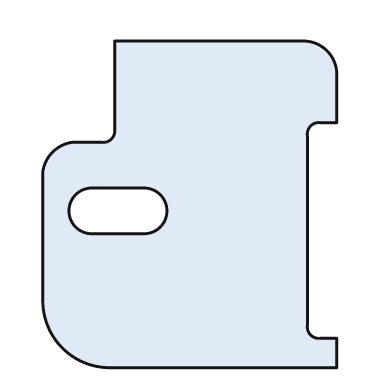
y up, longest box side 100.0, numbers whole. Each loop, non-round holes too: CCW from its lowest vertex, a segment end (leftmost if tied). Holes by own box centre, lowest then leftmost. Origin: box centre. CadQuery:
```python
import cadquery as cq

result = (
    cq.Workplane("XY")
    .moveTo(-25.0, -50.0)
    .lineTo(45.0, -50.0)
    .lineTo(45.0, -41.0)
    .lineTo(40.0, -41.0)
    .threePointArc((37.0, -40.0), (36.0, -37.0))
    .lineTo(36.0, 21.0)
    .threePointArc((37.0, 24.0), (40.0, 25.0))
    .lineTo(45.0, 25.0)
    .lineTo(45.0, 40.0)
    .threePointArc((42.0, 47.0), (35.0, 50.0))
    .lineTo(-23.0, 50.0)
    .lineTo(-23.0, 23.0)
    .threePointArc((-24.0, 20.0), (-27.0, 19.0))
    .lineTo(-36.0, 19.0)
    .threePointArc((-42.0, 16.0), (-45.0, 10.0))
    .lineTo(-45.0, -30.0)
    .threePointArc((-39.0, -44.0), (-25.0, -50.0))
    .close()
    .moveTo(-30.0, -9.0)
    .lineTo(-14.0, -9.0)
    .threePointArc((-7.0, -2.0), (-14.0, 5.0))
    .lineTo(-30.0, 5.0)
    .threePointArc((-37.0, -2.0), (-30.0, -9.0))
    .close()
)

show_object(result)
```